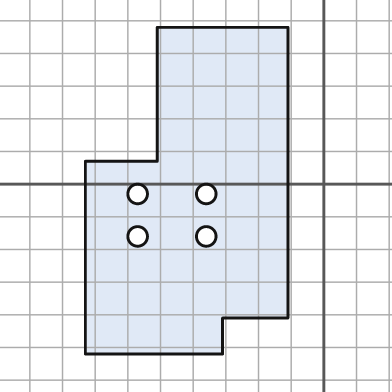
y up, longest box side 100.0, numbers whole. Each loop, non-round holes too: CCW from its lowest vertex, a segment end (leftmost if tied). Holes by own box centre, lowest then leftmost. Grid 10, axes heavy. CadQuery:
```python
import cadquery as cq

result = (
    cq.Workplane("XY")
    .moveTo(-73.0, -52.0)
    .lineTo(-31.0, -52.0)
    .lineTo(-31.0, -41.0)
    .lineTo(-11.0, -41.0)
    .lineTo(-11.0, 48.0)
    .lineTo(-51.0, 48.0)
    .lineTo(-51.0, 7.0)
    .lineTo(-73.0, 7.0)
    .close()
    .moveTo(-57.0, -16.0)
    .circle(3.0)
    .moveTo(-36.0, -16.0)
    .circle(3.0)
    .moveTo(-57.0, -3.0)
    .circle(3.0)
    .moveTo(-36.0, -3.0)
    .circle(3.0)
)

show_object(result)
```